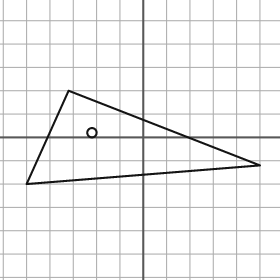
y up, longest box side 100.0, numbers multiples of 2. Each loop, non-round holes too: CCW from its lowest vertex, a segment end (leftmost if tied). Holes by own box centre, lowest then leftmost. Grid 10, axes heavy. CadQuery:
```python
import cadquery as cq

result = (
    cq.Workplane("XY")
    .moveTo(-50.0, -20.0)
    .lineTo(50.0, -12.0)
    .lineTo(-32.0, 20.0)
    .close()
    .moveTo(-22.0, 2.0)
    .circle(2.0)
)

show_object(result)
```